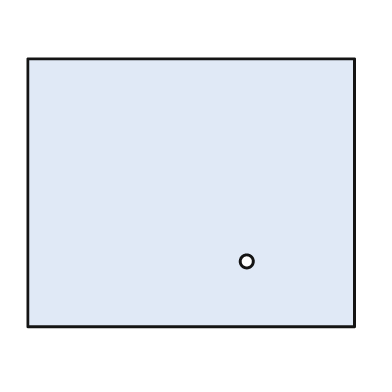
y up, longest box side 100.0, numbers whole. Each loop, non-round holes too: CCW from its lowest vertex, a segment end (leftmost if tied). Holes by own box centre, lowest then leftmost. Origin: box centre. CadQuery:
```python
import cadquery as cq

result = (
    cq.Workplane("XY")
    .moveTo(-50.0, -41.0)
    .lineTo(50.0, -41.0)
    .lineTo(50.0, 41.0)
    .lineTo(-50.0, 41.0)
    .close()
    .moveTo(17.0, -21.0)
    .circle(2.0)
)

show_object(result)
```